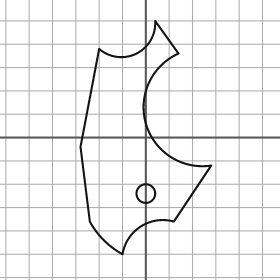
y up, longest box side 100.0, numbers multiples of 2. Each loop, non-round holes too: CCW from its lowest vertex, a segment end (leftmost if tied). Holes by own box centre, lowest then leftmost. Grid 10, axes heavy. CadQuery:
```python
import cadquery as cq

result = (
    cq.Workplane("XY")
    .moveTo(-10.0, -50.0)
    .threePointArc((-2.0, -38.0), (12.0, -36.0))
    .lineTo(28.0, -12.0)
    .threePointArc((0.0, 6.0), (14.0, 36.0))
    .lineTo(4.0, 50.0)
    .threePointArc((-4.0, 36.0), (-20.0, 38.0))
    .lineTo(-28.0, -4.0)
    .lineTo(-24.0, -36.0)
    .threePointArc((-18.0, -44.0), (-10.0, -50.0))
    .close()
    .moveTo(0.0, -24.0)
    .circle(4.0)
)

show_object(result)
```